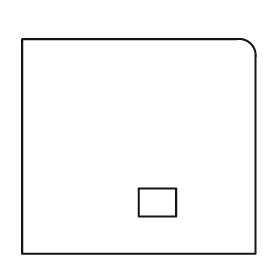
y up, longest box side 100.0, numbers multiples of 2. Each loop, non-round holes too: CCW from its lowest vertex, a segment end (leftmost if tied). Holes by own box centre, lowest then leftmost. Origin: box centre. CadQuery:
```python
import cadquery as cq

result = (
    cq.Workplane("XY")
    .moveTo(-50.0, -46.0)
    .lineTo(50.0, -46.0)
    .lineTo(50.0, 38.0)
    .threePointArc((48.0, 44.0), (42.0, 46.0))
    .lineTo(-50.0, 46.0)
    .close()
    .moveTo(0.0, -30.0)
    .lineTo(16.0, -30.0)
    .lineTo(16.0, -18.0)
    .lineTo(0.0, -18.0)
    .close()
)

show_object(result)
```